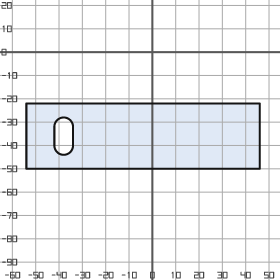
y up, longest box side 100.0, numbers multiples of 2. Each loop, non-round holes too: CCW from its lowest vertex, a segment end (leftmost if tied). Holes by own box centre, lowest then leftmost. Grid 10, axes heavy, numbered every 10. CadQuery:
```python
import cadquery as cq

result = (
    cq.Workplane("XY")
    .moveTo(-54.0, -50.0)
    .lineTo(46.0, -50.0)
    .lineTo(46.0, -22.0)
    .lineTo(-54.0, -22.0)
    .close()
    .moveTo(-42.0, -40.0)
    .threePointArc((-38.0, -44.0), (-34.0, -40.0))
    .lineTo(-34.0, -32.0)
    .threePointArc((-38.0, -28.0), (-42.0, -32.0))
    .close()
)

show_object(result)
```